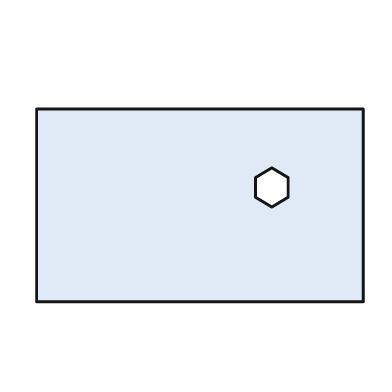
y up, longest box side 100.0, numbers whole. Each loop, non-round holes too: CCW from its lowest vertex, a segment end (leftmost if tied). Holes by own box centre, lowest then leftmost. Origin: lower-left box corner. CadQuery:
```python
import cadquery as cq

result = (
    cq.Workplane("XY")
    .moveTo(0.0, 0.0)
    .lineTo(100.0, 0.0)
    .lineTo(100.0, 59.0)
    .lineTo(0.0, 59.0)
    .close()
    .moveTo(72.0, 29.0)
    .lineTo(77.0, 32.0)
    .lineTo(77.0, 38.0)
    .lineTo(72.0, 41.0)
    .lineTo(67.0, 38.0)
    .lineTo(67.0, 32.0)
    .close()
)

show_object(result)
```